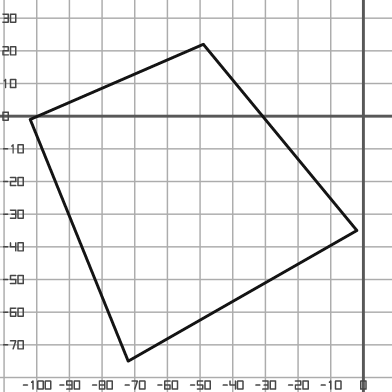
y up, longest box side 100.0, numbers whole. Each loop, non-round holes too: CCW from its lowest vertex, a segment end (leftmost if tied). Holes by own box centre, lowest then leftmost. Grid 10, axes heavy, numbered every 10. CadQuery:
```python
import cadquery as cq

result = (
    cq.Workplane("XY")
    .moveTo(-72.0, -75.0)
    .lineTo(-2.0, -35.0)
    .lineTo(-49.0, 22.0)
    .lineTo(-102.0, -1.0)
    .close()
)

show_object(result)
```